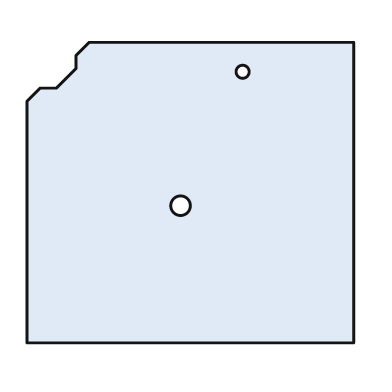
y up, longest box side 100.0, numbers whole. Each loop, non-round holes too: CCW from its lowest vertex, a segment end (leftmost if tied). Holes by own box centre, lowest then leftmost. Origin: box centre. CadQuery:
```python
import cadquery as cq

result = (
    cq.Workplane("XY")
    .moveTo(-50.0, -46.0)
    .lineTo(50.0, -46.0)
    .lineTo(50.0, 46.0)
    .lineTo(-31.0, 46.0)
    .lineTo(-35.0, 42.0)
    .lineTo(-35.0, 38.0)
    .lineTo(-41.0, 32.0)
    .lineTo(-46.0, 32.0)
    .lineTo(-50.0, 28.0)
    .close()
    .moveTo(-3.0, -4.0)
    .circle(3.0)
    .moveTo(16.0, 37.0)
    .circle(2.0)
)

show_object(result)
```